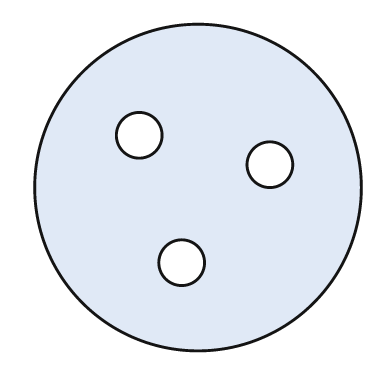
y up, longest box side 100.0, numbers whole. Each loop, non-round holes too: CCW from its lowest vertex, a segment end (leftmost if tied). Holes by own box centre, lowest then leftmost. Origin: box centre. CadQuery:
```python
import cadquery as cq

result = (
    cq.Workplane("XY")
    .moveTo(0.0, 0.0)
    .circle(50.0)
    .moveTo(-5.0, -23.0)
    .circle(7.0)
    .moveTo(22.0, 7.0)
    .circle(7.0)
    .moveTo(-18.0, 16.0)
    .circle(7.0)
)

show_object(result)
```